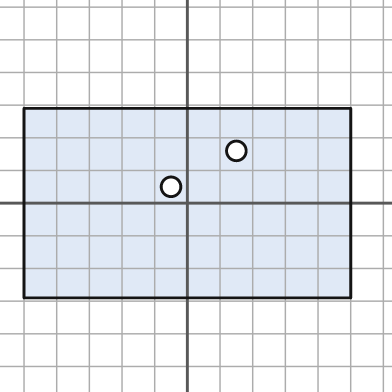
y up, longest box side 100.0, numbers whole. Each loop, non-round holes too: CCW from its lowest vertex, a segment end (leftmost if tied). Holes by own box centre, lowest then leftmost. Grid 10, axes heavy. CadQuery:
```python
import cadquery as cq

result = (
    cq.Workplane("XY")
    .moveTo(-50.0, -29.0)
    .lineTo(50.0, -29.0)
    .lineTo(50.0, 29.0)
    .lineTo(-50.0, 29.0)
    .close()
    .moveTo(-5.0, 5.0)
    .circle(3.0)
    .moveTo(15.0, 16.0)
    .circle(3.0)
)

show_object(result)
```